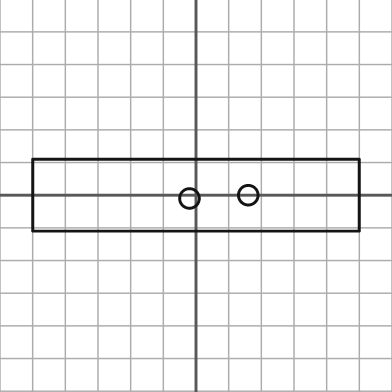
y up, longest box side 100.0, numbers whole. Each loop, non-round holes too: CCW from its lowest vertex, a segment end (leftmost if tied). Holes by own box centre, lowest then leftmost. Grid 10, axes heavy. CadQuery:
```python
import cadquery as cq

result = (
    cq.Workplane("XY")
    .moveTo(-50.0, -11.0)
    .lineTo(50.0, -11.0)
    .lineTo(50.0, 11.0)
    .lineTo(-50.0, 11.0)
    .close()
    .moveTo(-2.0, -1.0)
    .circle(3.0)
    .moveTo(16.0, 0.0)
    .circle(3.0)
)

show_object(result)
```